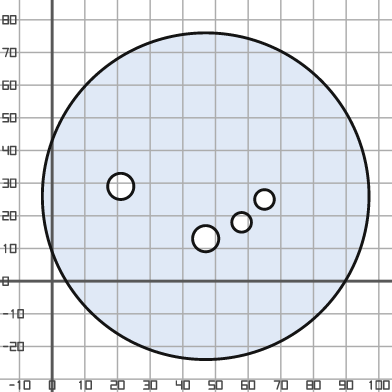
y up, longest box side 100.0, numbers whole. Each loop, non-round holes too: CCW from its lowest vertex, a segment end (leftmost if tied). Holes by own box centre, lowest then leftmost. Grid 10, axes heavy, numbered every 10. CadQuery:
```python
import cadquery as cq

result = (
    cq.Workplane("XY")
    .moveTo(47.0, 26.0)
    .circle(50.0)
    .moveTo(47.0, 13.0)
    .circle(4.0)
    .moveTo(58.0, 18.0)
    .circle(3.0)
    .moveTo(65.0, 25.0)
    .circle(3.0)
    .moveTo(21.0, 29.0)
    .circle(4.0)
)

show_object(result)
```